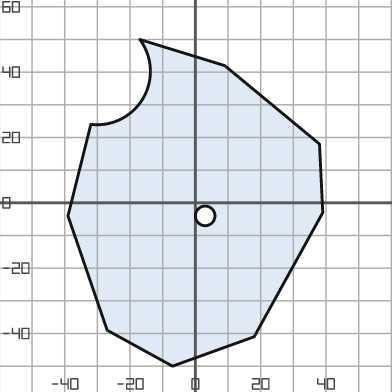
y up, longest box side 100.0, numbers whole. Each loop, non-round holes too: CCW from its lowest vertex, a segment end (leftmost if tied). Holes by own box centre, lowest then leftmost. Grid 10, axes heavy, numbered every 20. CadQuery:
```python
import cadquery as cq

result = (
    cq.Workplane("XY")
    .moveTo(-7.0, -50.0)
    .lineTo(18.0, -41.0)
    .lineTo(39.0, -3.0)
    .lineTo(38.0, 18.0)
    .lineTo(9.0, 42.0)
    .lineTo(-17.0, 50.0)
    .threePointArc((-16.0, 32.0), (-32.0, 24.0))
    .lineTo(-39.0, -4.0)
    .lineTo(-27.0, -39.0)
    .close()
    .moveTo(3.0, -4.0)
    .circle(3.0)
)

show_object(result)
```